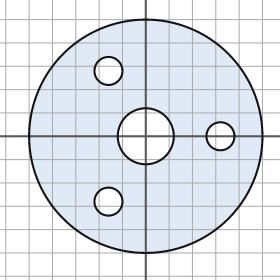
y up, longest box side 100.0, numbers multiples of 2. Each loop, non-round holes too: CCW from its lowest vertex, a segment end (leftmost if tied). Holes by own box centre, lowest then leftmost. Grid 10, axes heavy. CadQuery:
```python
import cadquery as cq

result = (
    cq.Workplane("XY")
    .moveTo(0.0, 0.0)
    .circle(50.0)
    .moveTo(-16.0, -28.0)
    .circle(6.0)
    .moveTo(0.0, 0.0)
    .circle(12.0)
    .moveTo(32.0, 0.0)
    .circle(6.0)
    .moveTo(-16.0, 28.0)
    .circle(6.0)
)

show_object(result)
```